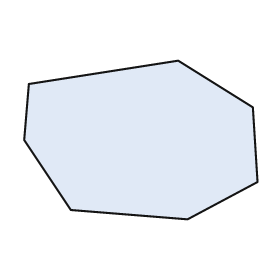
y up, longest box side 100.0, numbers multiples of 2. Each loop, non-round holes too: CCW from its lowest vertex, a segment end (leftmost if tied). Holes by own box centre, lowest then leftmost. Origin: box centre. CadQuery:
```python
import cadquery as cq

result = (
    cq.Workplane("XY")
    .moveTo(20.0, -34.0)
    .lineTo(50.0, -18.0)
    .lineTo(48.0, 14.0)
    .lineTo(16.0, 34.0)
    .lineTo(-48.0, 24.0)
    .lineTo(-50.0, 0.0)
    .lineTo(-30.0, -30.0)
    .close()
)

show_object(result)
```